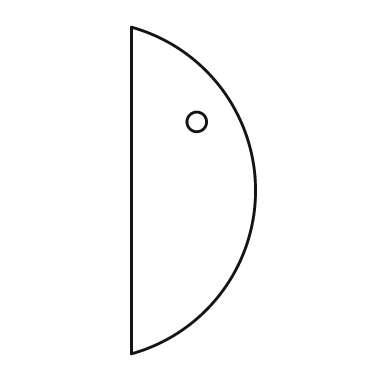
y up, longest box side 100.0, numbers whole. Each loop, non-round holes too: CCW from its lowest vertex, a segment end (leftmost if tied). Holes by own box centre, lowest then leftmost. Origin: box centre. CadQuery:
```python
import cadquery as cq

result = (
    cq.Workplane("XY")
    .moveTo(-19.0, -50.0)
    .threePointArc((19.0, 0.0), (-19.0, 50.0))
    .close()
    .moveTo(1.0, 21.0)
    .circle(3.0)
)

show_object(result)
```